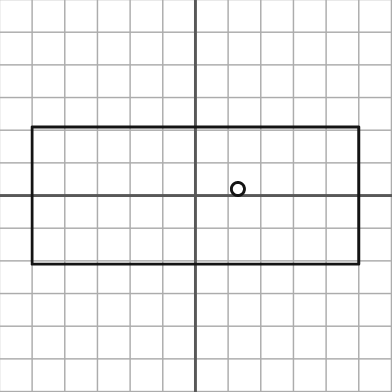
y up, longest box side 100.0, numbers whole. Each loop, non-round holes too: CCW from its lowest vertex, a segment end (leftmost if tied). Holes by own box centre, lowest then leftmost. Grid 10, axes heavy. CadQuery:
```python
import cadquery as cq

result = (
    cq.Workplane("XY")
    .moveTo(-50.0, -21.0)
    .lineTo(50.0, -21.0)
    .lineTo(50.0, 21.0)
    .lineTo(-50.0, 21.0)
    .close()
    .moveTo(13.0, 2.0)
    .circle(2.0)
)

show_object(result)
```